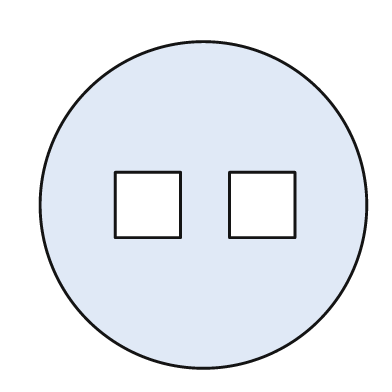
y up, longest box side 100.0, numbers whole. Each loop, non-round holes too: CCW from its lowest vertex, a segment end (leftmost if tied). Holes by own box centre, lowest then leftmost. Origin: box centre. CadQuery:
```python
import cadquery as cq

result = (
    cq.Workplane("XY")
    .moveTo(0.0, 0.0)
    .circle(50.0)
    .moveTo(-27.0, -10.0)
    .lineTo(-7.0, -10.0)
    .lineTo(-7.0, 10.0)
    .lineTo(-27.0, 10.0)
    .close()
    .moveTo(8.0, -10.0)
    .lineTo(28.0, -10.0)
    .lineTo(28.0, 10.0)
    .lineTo(8.0, 10.0)
    .close()
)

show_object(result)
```